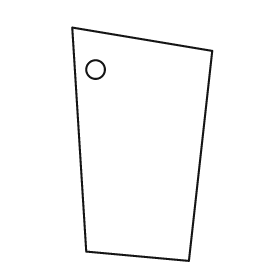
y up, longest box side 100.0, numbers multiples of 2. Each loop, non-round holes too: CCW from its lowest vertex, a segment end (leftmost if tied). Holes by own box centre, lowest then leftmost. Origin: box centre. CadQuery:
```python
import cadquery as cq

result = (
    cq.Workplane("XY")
    .moveTo(20.0, -50.0)
    .lineTo(30.0, 40.0)
    .lineTo(-30.0, 50.0)
    .lineTo(-24.0, -46.0)
    .close()
    .moveTo(-20.0, 32.0)
    .circle(4.0)
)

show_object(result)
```